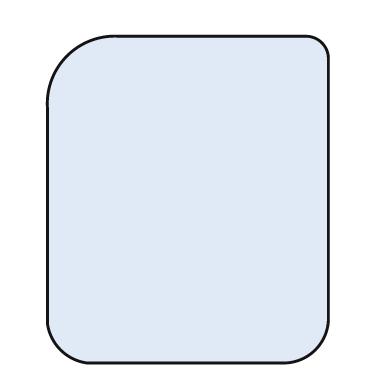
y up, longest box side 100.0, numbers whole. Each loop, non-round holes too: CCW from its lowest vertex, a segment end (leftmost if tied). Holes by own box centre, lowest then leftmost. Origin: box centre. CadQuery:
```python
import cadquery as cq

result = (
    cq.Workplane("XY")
    .moveTo(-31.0, -50.0)
    .lineTo(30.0, -50.0)
    .threePointArc((39.0, -46.0), (43.0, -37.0))
    .lineTo(43.0, 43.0)
    .threePointArc((41.0, 48.0), (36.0, 50.0))
    .lineTo(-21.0, 50.0)
    .threePointArc((-37.0, 44.0), (-43.0, 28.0))
    .lineTo(-43.0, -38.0)
    .threePointArc((-39.0, -46.0), (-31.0, -50.0))
    .close()
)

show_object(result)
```